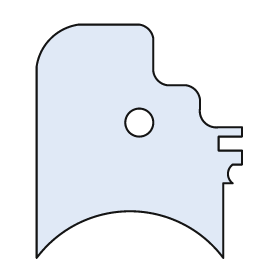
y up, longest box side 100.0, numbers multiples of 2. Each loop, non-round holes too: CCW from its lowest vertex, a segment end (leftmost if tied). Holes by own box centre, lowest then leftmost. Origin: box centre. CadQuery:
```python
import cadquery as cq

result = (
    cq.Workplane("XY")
    .moveTo(-44.0, -50.0)
    .threePointArc((-4.0, -30.0), (36.0, -50.0))
    .lineTo(36.0, -18.0)
    .lineTo(40.0, -18.0)
    .threePointArc((38.0, -14.0), (40.0, -10.0))
    .lineTo(44.0, -10.0)
    .lineTo(44.0, -4.0)
    .lineTo(34.0, -4.0)
    .lineTo(34.0, 2.0)
    .lineTo(44.0, 2.0)
    .lineTo(44.0, 6.0)
    .lineTo(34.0, 6.0)
    .threePointArc((28.0, 8.0), (26.0, 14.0))
    .lineTo(26.0, 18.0)
    .threePointArc((24.0, 22.0), (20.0, 24.0))
    .lineTo(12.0, 24.0)
    .threePointArc((8.0, 26.0), (6.0, 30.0))
    .lineTo(6.0, 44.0)
    .threePointArc((4.0, 48.0), (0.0, 50.0))
    .lineTo(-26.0, 50.0)
    .threePointArc((-38.0, 44.0), (-44.0, 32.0))
    .close()
    .moveTo(0.0, 8.0)
    .circle(6.0)
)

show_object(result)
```